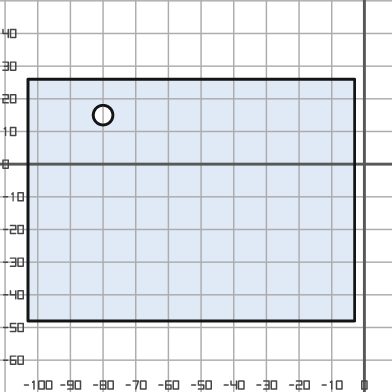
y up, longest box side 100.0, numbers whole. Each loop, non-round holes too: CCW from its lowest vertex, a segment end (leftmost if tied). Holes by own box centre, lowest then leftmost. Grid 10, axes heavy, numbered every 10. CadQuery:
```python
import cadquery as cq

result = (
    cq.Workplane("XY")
    .moveTo(-103.0, -48.0)
    .lineTo(-3.0, -48.0)
    .lineTo(-3.0, 26.0)
    .lineTo(-103.0, 26.0)
    .close()
    .moveTo(-80.0, 15.0)
    .circle(3.0)
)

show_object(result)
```